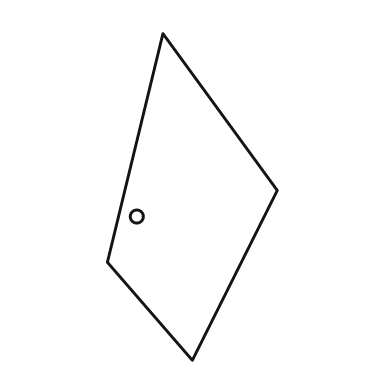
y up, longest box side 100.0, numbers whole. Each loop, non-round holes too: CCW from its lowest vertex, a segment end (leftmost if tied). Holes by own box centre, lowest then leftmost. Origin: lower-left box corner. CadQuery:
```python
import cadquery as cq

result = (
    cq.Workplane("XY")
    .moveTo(26.0, 0.0)
    .lineTo(52.0, 52.0)
    .lineTo(17.0, 100.0)
    .lineTo(0.0, 30.0)
    .close()
    .moveTo(9.0, 44.0)
    .circle(2.0)
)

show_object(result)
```